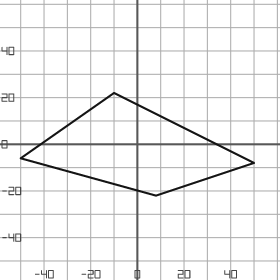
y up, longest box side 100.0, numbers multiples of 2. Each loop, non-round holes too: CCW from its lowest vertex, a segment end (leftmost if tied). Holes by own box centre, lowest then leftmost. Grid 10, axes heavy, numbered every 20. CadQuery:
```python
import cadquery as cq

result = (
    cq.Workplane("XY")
    .moveTo(8.0, -22.0)
    .lineTo(50.0, -8.0)
    .lineTo(-10.0, 22.0)
    .lineTo(-50.0, -6.0)
    .close()
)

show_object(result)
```